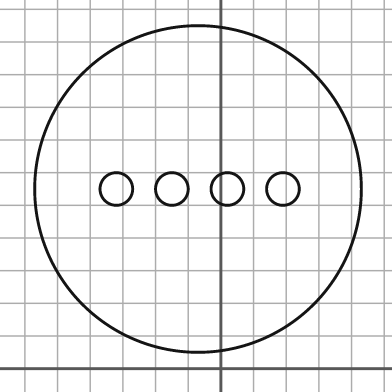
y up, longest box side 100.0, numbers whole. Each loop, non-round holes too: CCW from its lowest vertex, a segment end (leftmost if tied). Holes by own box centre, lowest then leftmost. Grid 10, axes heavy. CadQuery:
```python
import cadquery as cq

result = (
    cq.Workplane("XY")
    .moveTo(-7.0, 55.0)
    .circle(50.0)
    .moveTo(-32.0, 55.0)
    .circle(5.0)
    .moveTo(-15.0, 55.0)
    .circle(5.0)
    .moveTo(2.0, 55.0)
    .circle(5.0)
    .moveTo(19.0, 55.0)
    .circle(5.0)
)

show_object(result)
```